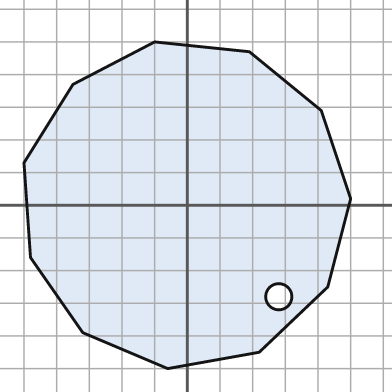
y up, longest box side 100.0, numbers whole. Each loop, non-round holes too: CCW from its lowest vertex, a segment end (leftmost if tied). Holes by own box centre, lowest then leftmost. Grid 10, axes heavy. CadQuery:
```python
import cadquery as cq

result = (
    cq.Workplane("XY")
    .moveTo(-6.0, -50.0)
    .lineTo(22.0, -45.0)
    .lineTo(43.0, -25.0)
    .lineTo(50.0, 2.0)
    .lineTo(41.0, 29.0)
    .lineTo(19.0, 47.0)
    .lineTo(-10.0, 50.0)
    .lineTo(-35.0, 37.0)
    .lineTo(-50.0, 13.0)
    .lineTo(-48.0, -16.0)
    .lineTo(-32.0, -39.0)
    .close()
    .moveTo(28.0, -28.0)
    .circle(4.0)
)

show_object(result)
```